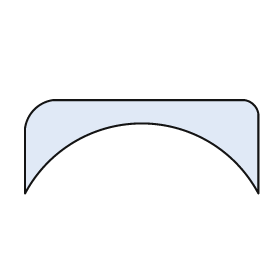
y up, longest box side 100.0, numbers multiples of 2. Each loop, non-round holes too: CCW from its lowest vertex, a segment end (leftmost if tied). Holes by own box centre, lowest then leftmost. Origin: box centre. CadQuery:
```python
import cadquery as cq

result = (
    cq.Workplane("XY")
    .moveTo(-50.0, -20.0)
    .threePointArc((0.0, 10.0), (50.0, -20.0))
    .lineTo(50.0, 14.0)
    .threePointArc((48.0, 18.0), (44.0, 20.0))
    .lineTo(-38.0, 20.0)
    .threePointArc((-46.0, 16.0), (-50.0, 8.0))
    .close()
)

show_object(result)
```